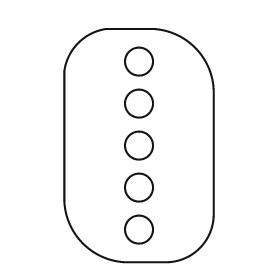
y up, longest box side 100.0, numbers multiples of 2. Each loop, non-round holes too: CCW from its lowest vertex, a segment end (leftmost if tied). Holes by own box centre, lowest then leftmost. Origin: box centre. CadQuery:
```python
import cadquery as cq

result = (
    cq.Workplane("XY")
    .moveTo(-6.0, -50.0)
    .lineTo(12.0, -50.0)
    .threePointArc((26.0, -44.0), (32.0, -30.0))
    .lineTo(32.0, 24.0)
    .threePointArc((24.0, 42.0), (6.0, 50.0))
    .lineTo(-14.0, 50.0)
    .threePointArc((-26.0, 44.0), (-32.0, 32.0))
    .lineTo(-32.0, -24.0)
    .threePointArc((-24.0, -42.0), (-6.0, -50.0))
    .close()
    .moveTo(0.0, -36.0)
    .circle(6.0)
    .moveTo(0.0, -18.0)
    .circle(6.0)
    .moveTo(0.0, 0.0)
    .circle(6.0)
    .moveTo(0.0, 18.0)
    .circle(6.0)
    .moveTo(0.0, 36.0)
    .circle(6.0)
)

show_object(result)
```